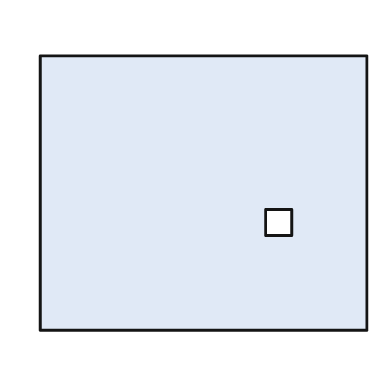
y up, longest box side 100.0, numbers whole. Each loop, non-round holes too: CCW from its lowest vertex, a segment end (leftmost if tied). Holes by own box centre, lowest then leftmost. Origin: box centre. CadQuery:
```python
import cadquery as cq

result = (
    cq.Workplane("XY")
    .moveTo(-50.0, -42.0)
    .lineTo(50.0, -42.0)
    .lineTo(50.0, 42.0)
    .lineTo(-50.0, 42.0)
    .close()
    .moveTo(19.0, -13.0)
    .lineTo(27.0, -13.0)
    .lineTo(27.0, -5.0)
    .lineTo(19.0, -5.0)
    .close()
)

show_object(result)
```